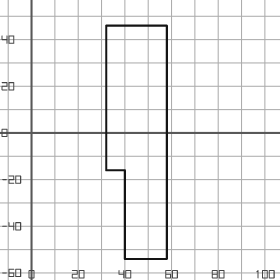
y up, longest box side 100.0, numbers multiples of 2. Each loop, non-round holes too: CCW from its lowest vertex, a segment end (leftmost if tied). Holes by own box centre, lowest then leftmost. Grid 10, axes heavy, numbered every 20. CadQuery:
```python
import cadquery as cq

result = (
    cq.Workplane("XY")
    .moveTo(40.0, -54.0)
    .lineTo(58.0, -54.0)
    .lineTo(58.0, 46.0)
    .lineTo(32.0, 46.0)
    .lineTo(32.0, -16.0)
    .lineTo(40.0, -16.0)
    .close()
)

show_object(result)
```